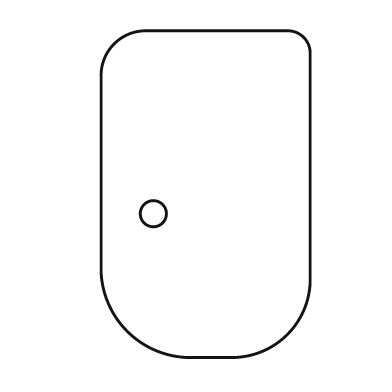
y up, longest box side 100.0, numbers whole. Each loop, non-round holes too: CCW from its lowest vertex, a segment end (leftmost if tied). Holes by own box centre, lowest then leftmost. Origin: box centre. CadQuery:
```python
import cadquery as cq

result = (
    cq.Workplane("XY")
    .moveTo(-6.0, -50.0)
    .lineTo(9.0, -50.0)
    .threePointArc((25.0, -43.0), (32.0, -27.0))
    .lineTo(32.0, 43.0)
    .threePointArc((30.0, 48.0), (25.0, 50.0))
    .lineTo(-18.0, 50.0)
    .threePointArc((-28.0, 46.0), (-32.0, 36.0))
    .lineTo(-32.0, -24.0)
    .threePointArc((-24.0, -42.0), (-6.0, -50.0))
    .close()
    .moveTo(-16.0, -6.0)
    .circle(4.0)
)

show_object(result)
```